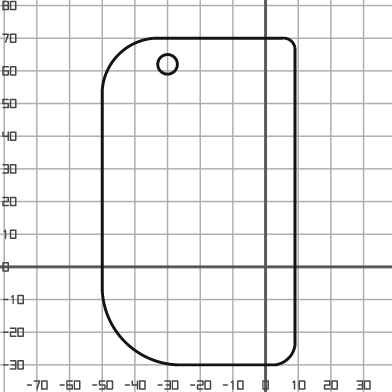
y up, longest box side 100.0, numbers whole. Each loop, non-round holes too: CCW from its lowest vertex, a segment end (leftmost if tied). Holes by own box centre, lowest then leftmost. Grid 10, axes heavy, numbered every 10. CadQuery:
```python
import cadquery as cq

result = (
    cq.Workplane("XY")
    .moveTo(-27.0, -30.0)
    .lineTo(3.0, -30.0)
    .threePointArc((7.0, -28.0), (9.0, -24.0))
    .lineTo(9.0, 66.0)
    .threePointArc((8.0, 69.0), (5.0, 70.0))
    .lineTo(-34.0, 70.0)
    .threePointArc((-45.0, 65.0), (-50.0, 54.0))
    .lineTo(-50.0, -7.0)
    .threePointArc((-43.0, -23.0), (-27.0, -30.0))
    .close()
    .moveTo(-30.0, 62.0)
    .circle(3.0)
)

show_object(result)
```